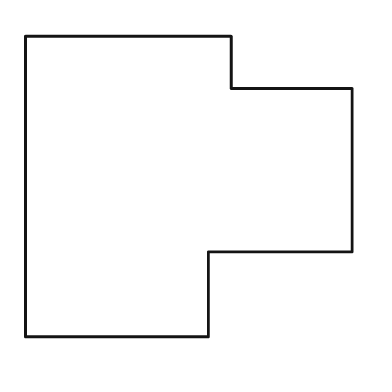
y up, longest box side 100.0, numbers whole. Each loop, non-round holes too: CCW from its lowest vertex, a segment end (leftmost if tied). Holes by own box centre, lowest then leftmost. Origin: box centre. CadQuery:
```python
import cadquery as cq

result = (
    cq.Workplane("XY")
    .moveTo(-50.0, -46.0)
    .lineTo(6.0, -46.0)
    .lineTo(6.0, -20.0)
    .lineTo(50.0, -20.0)
    .lineTo(50.0, 30.0)
    .lineTo(13.0, 30.0)
    .lineTo(13.0, 46.0)
    .lineTo(-50.0, 46.0)
    .close()
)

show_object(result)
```